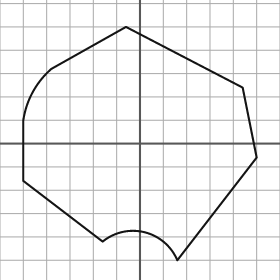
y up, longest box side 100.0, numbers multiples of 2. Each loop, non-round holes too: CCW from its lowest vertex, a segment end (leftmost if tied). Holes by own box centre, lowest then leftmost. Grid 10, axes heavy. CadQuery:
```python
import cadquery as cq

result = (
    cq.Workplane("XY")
    .moveTo(16.0, -50.0)
    .lineTo(50.0, -6.0)
    .lineTo(44.0, 24.0)
    .lineTo(-6.0, 50.0)
    .lineTo(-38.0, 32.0)
    .threePointArc((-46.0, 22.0), (-50.0, 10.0))
    .lineTo(-50.0, -16.0)
    .lineTo(-16.0, -42.0)
    .threePointArc((2.0, -38.0), (16.0, -50.0))
    .close()
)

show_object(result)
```